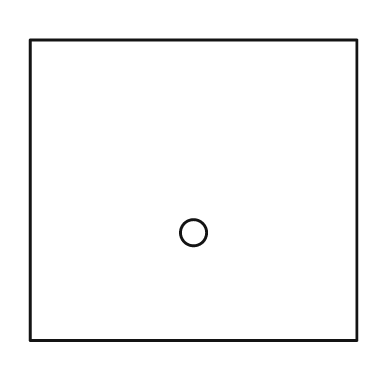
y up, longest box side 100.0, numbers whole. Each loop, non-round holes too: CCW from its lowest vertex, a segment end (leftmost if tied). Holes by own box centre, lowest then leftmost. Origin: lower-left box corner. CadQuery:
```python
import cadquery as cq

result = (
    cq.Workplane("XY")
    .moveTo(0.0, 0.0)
    .lineTo(100.0, 0.0)
    .lineTo(100.0, 92.0)
    .lineTo(0.0, 92.0)
    .close()
    .moveTo(50.0, 33.0)
    .circle(4.0)
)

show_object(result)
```